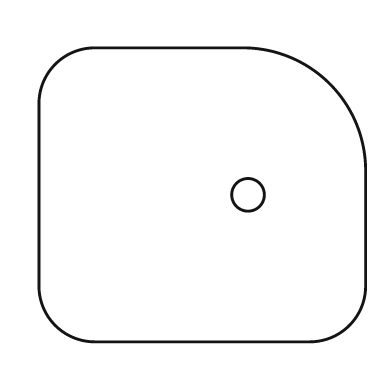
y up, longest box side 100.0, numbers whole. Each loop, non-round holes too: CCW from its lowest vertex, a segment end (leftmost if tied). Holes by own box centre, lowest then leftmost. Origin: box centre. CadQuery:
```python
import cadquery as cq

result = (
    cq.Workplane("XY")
    .moveTo(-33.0, -45.0)
    .lineTo(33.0, -45.0)
    .threePointArc((45.0, -40.0), (50.0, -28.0))
    .lineTo(50.0, 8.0)
    .threePointArc((39.0, 34.0), (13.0, 45.0))
    .lineTo(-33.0, 45.0)
    .threePointArc((-45.0, 40.0), (-50.0, 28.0))
    .lineTo(-50.0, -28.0)
    .threePointArc((-45.0, -40.0), (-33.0, -45.0))
    .close()
    .moveTo(14.0, 0.0)
    .circle(5.0)
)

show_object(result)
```